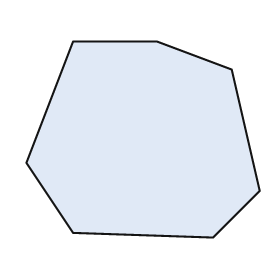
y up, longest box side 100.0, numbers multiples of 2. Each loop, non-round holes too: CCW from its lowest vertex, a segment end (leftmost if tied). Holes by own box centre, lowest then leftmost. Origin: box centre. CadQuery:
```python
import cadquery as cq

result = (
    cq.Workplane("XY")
    .moveTo(30.0, -42.0)
    .lineTo(50.0, -22.0)
    .lineTo(38.0, 30.0)
    .lineTo(6.0, 42.0)
    .lineTo(-30.0, 42.0)
    .lineTo(-50.0, -10.0)
    .lineTo(-30.0, -40.0)
    .close()
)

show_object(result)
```